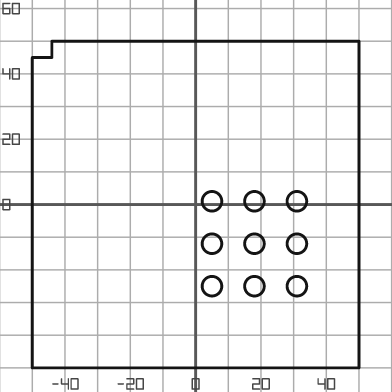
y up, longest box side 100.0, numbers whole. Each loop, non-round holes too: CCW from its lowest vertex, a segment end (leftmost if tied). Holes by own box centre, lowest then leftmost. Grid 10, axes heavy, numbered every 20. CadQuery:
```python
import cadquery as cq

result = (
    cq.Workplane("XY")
    .moveTo(-50.0, -50.0)
    .lineTo(50.0, -50.0)
    .lineTo(50.0, 50.0)
    .lineTo(-44.0, 50.0)
    .lineTo(-44.0, 45.0)
    .lineTo(-50.0, 45.0)
    .close()
    .moveTo(5.0, -25.0)
    .circle(3.0)
    .moveTo(18.0, -25.0)
    .circle(3.0)
    .moveTo(31.0, -25.0)
    .circle(3.0)
    .moveTo(5.0, -12.0)
    .circle(3.0)
    .moveTo(18.0, -12.0)
    .circle(3.0)
    .moveTo(31.0, -12.0)
    .circle(3.0)
    .moveTo(5.0, 1.0)
    .circle(3.0)
    .moveTo(18.0, 1.0)
    .circle(3.0)
    .moveTo(31.0, 1.0)
    .circle(3.0)
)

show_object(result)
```